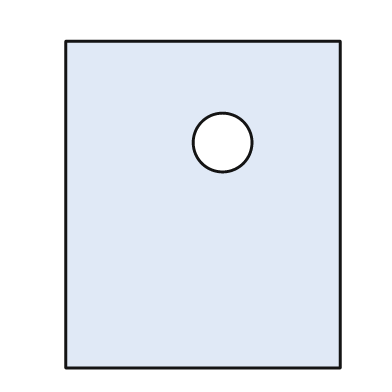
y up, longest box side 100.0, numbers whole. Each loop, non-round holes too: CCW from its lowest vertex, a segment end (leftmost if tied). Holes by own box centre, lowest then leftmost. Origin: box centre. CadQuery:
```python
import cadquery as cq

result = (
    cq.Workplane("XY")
    .moveTo(-42.0, -50.0)
    .lineTo(42.0, -50.0)
    .lineTo(42.0, 50.0)
    .lineTo(-42.0, 50.0)
    .close()
    .moveTo(6.0, 19.0)
    .circle(9.0)
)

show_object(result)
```